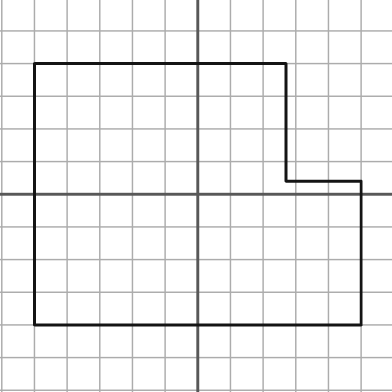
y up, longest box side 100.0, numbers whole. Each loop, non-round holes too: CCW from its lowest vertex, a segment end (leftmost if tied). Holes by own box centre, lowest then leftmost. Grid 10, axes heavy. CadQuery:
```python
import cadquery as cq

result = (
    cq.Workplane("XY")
    .moveTo(-50.0, -40.0)
    .lineTo(50.0, -40.0)
    .lineTo(50.0, 4.0)
    .lineTo(27.0, 4.0)
    .lineTo(27.0, 40.0)
    .lineTo(-50.0, 40.0)
    .close()
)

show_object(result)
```